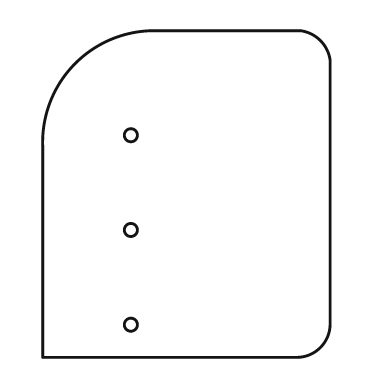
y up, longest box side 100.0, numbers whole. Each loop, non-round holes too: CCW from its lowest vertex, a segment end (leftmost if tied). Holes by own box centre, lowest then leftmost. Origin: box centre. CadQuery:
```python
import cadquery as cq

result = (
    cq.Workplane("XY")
    .moveTo(-44.0, -50.0)
    .lineTo(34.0, -50.0)
    .threePointArc((41.0, -47.0), (44.0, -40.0))
    .lineTo(44.0, 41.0)
    .threePointArc((41.0, 47.0), (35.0, 50.0))
    .lineTo(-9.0, 50.0)
    .threePointArc((-34.0, 40.0), (-44.0, 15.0))
    .close()
    .moveTo(-17.0, -40.0)
    .circle(2.0)
    .moveTo(-17.0, -11.0)
    .circle(2.0)
    .moveTo(-17.0, 18.0)
    .circle(2.0)
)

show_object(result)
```